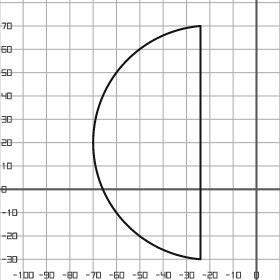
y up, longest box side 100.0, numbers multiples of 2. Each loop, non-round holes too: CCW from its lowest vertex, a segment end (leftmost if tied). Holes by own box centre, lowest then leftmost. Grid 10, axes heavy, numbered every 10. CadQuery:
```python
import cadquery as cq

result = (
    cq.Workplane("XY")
    .moveTo(-24.0, -30.0)
    .lineTo(-24.0, 70.0)
    .threePointArc((-70.0, 20.0), (-24.0, -30.0))
    .close()
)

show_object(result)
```